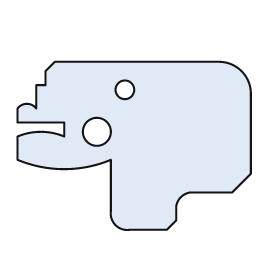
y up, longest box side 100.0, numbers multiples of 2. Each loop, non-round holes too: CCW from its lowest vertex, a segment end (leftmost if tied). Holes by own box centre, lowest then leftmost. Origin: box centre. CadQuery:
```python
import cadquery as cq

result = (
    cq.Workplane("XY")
    .moveTo(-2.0, -36.0)
    .lineTo(14.0, -36.0)
    .lineTo(18.0, -32.0)
    .lineTo(18.0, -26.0)
    .threePointArc((20.0, -22.0), (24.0, -20.0))
    .lineTo(42.0, -20.0)
    .lineTo(50.0, -12.0)
    .lineTo(50.0, 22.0)
    .threePointArc((46.0, 32.0), (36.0, 36.0))
    .lineTo(-34.0, 36.0)
    .lineTo(-38.0, 32.0)
    .lineTo(-38.0, 26.0)
    .lineTo(-42.0, 26.0)
    .lineTo(-42.0, 16.0)
    .threePointArc((-46.0, 18.0), (-50.0, 16.0))
    .lineTo(-50.0, 10.0)
    .lineTo(-30.0, 10.0)
    .lineTo(-30.0, 4.0)
    .threePointArc((-40.0, 6.0), (-50.0, 4.0))
    .lineTo(-50.0, -6.0)
    .threePointArc((-30.0, -10.0), (-10.0, -6.0))
    .lineTo(-10.0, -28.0)
    .threePointArc((-8.0, -34.0), (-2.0, -36.0))
    .close()
    .moveTo(-16.0, 6.0)
    .circle(6.0)
    .moveTo(-4.0, 24.0)
    .circle(4.0)
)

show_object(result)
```